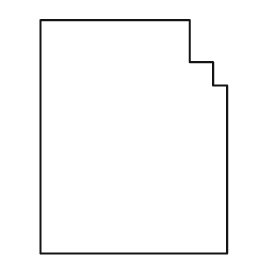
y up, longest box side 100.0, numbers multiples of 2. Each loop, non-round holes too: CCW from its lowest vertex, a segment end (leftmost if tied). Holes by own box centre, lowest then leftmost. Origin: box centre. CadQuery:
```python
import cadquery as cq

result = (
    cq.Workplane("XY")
    .moveTo(-40.0, -50.0)
    .lineTo(40.0, -50.0)
    .lineTo(40.0, 22.0)
    .lineTo(34.0, 22.0)
    .lineTo(34.0, 32.0)
    .lineTo(24.0, 32.0)
    .lineTo(24.0, 50.0)
    .lineTo(-40.0, 50.0)
    .close()
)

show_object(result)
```